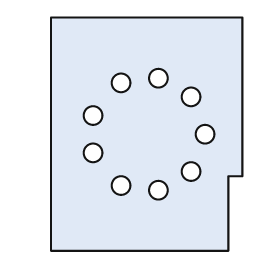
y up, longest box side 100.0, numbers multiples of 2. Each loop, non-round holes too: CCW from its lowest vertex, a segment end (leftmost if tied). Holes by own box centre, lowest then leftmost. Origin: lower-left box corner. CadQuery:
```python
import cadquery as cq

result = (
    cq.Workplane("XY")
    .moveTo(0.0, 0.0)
    .lineTo(76.0, 0.0)
    .lineTo(76.0, 32.0)
    .lineTo(82.0, 32.0)
    .lineTo(82.0, 100.0)
    .lineTo(0.0, 100.0)
    .close()
    .moveTo(46.0, 26.0)
    .circle(4.0)
    .moveTo(30.0, 28.0)
    .circle(4.0)
    .moveTo(60.0, 34.0)
    .circle(4.0)
    .moveTo(18.0, 42.0)
    .circle(4.0)
    .moveTo(66.0, 50.0)
    .circle(4.0)
    .moveTo(18.0, 58.0)
    .circle(4.0)
    .moveTo(60.0, 66.0)
    .circle(4.0)
    .moveTo(30.0, 72.0)
    .circle(4.0)
    .moveTo(46.0, 74.0)
    .circle(4.0)
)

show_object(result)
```